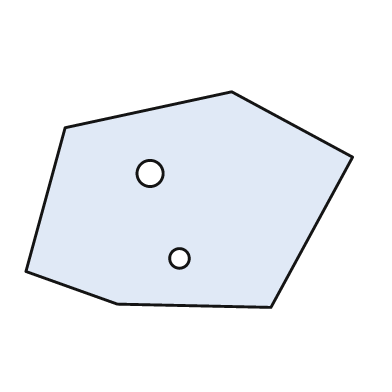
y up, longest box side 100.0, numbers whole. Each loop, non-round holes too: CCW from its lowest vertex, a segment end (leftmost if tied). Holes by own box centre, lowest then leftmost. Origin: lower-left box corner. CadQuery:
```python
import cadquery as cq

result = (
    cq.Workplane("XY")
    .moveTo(75.0, 0.0)
    .lineTo(100.0, 46.0)
    .lineTo(63.0, 66.0)
    .lineTo(12.0, 55.0)
    .lineTo(0.0, 11.0)
    .lineTo(28.0, 1.0)
    .close()
    .moveTo(47.0, 15.0)
    .circle(3.0)
    .moveTo(38.0, 41.0)
    .circle(4.0)
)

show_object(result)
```